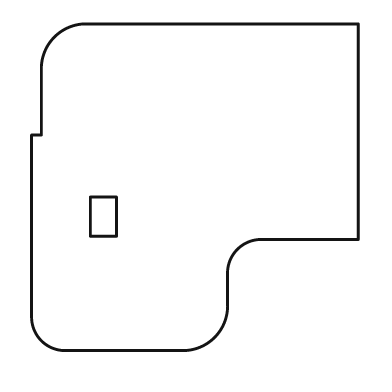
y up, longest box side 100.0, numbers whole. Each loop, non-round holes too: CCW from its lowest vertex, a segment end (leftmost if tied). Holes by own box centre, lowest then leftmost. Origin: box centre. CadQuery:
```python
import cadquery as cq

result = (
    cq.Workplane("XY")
    .moveTo(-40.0, -50.0)
    .lineTo(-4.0, -50.0)
    .threePointArc((6.0, -46.0), (10.0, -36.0))
    .lineTo(10.0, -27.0)
    .threePointArc((13.0, -19.0), (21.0, -16.0))
    .lineTo(50.0, -16.0)
    .lineTo(50.0, 50.0)
    .lineTo(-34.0, 50.0)
    .threePointArc((-43.0, 46.0), (-47.0, 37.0))
    .lineTo(-47.0, 16.0)
    .lineTo(-50.0, 16.0)
    .lineTo(-50.0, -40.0)
    .threePointArc((-47.0, -47.0), (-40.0, -50.0))
    .close()
    .moveTo(-32.0, -15.0)
    .lineTo(-24.0, -15.0)
    .lineTo(-24.0, -3.0)
    .lineTo(-32.0, -3.0)
    .close()
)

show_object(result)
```